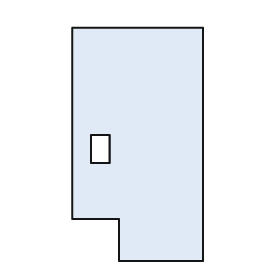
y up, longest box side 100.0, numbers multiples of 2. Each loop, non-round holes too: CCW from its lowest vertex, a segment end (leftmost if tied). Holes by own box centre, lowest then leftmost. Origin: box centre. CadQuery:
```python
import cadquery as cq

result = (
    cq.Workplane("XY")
    .moveTo(-8.0, -50.0)
    .lineTo(28.0, -50.0)
    .lineTo(28.0, 50.0)
    .lineTo(-28.0, 50.0)
    .lineTo(-28.0, -32.0)
    .lineTo(-8.0, -32.0)
    .close()
    .moveTo(-20.0, -8.0)
    .lineTo(-12.0, -8.0)
    .lineTo(-12.0, 4.0)
    .lineTo(-20.0, 4.0)
    .close()
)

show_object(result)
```